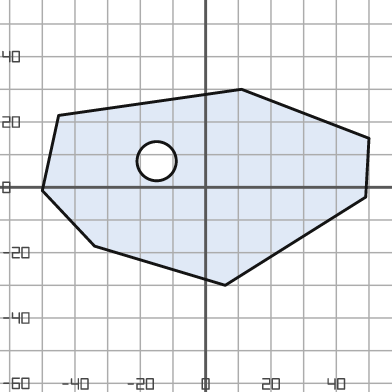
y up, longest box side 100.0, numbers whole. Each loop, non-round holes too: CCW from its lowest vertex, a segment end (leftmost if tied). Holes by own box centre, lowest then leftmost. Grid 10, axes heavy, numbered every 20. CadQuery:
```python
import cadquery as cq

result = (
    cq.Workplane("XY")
    .moveTo(6.0, -30.0)
    .lineTo(49.0, -3.0)
    .lineTo(50.0, 15.0)
    .lineTo(11.0, 30.0)
    .lineTo(-45.0, 22.0)
    .lineTo(-50.0, -1.0)
    .lineTo(-34.0, -18.0)
    .close()
    .moveTo(-15.0, 8.0)
    .circle(6.0)
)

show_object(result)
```